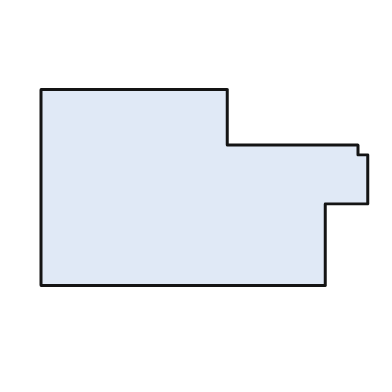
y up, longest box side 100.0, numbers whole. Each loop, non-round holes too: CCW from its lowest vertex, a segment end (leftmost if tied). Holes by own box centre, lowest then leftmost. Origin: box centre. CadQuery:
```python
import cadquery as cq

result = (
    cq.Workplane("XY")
    .moveTo(-50.0, -30.0)
    .lineTo(37.0, -30.0)
    .lineTo(37.0, -5.0)
    .lineTo(50.0, -5.0)
    .lineTo(50.0, 10.0)
    .lineTo(47.0, 10.0)
    .lineTo(47.0, 13.0)
    .lineTo(7.0, 13.0)
    .lineTo(7.0, 30.0)
    .lineTo(-50.0, 30.0)
    .close()
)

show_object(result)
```